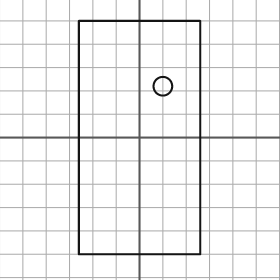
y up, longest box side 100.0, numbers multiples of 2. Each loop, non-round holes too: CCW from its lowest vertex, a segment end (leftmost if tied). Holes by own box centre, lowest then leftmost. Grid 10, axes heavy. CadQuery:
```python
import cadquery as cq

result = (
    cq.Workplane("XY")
    .moveTo(-26.0, -50.0)
    .lineTo(26.0, -50.0)
    .lineTo(26.0, 50.0)
    .lineTo(-26.0, 50.0)
    .close()
    .moveTo(10.0, 22.0)
    .circle(4.0)
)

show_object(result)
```